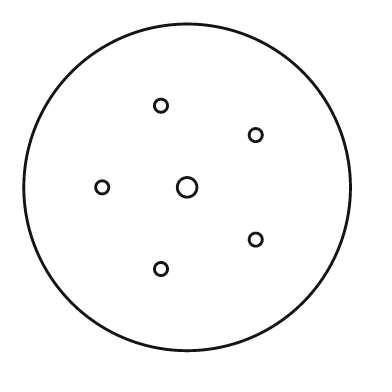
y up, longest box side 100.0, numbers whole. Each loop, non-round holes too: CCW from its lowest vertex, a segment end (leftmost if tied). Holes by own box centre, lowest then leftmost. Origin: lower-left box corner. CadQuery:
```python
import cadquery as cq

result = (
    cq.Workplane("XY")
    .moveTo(50.0, 50.0)
    .circle(50.0)
    .moveTo(42.0, 25.0)
    .circle(2.0)
    .moveTo(71.0, 34.0)
    .circle(2.0)
    .moveTo(24.0, 50.0)
    .circle(2.0)
    .moveTo(50.0, 50.0)
    .circle(3.0)
    .moveTo(71.0, 66.0)
    .circle(2.0)
    .moveTo(42.0, 75.0)
    .circle(2.0)
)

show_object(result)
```